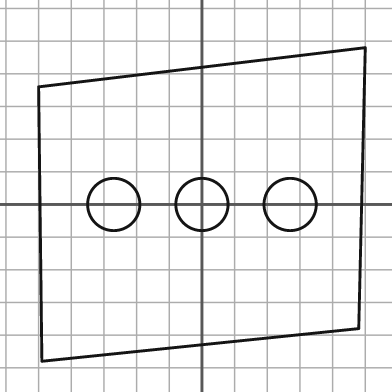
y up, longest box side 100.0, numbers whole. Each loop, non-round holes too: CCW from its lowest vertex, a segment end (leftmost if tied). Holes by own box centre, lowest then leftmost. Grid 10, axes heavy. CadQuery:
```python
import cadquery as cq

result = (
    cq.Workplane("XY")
    .moveTo(-49.0, -48.0)
    .lineTo(48.0, -38.0)
    .lineTo(50.0, 48.0)
    .lineTo(-50.0, 36.0)
    .close()
    .moveTo(-27.0, 0.0)
    .circle(8.0)
    .moveTo(0.0, 0.0)
    .circle(8.0)
    .moveTo(27.0, 0.0)
    .circle(8.0)
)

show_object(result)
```